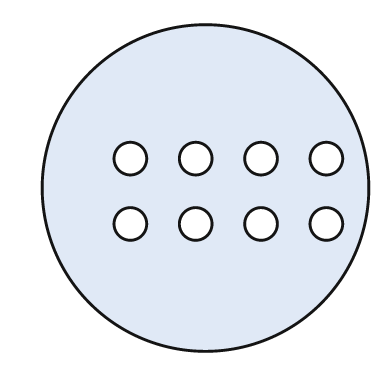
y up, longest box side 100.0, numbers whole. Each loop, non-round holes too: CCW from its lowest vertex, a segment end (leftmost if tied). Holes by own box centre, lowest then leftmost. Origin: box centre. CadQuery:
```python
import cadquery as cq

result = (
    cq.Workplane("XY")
    .moveTo(0.0, 0.0)
    .circle(50.0)
    .moveTo(-23.0, -11.0)
    .circle(5.0)
    .moveTo(-3.0, -11.0)
    .circle(5.0)
    .moveTo(17.0, -11.0)
    .circle(5.0)
    .moveTo(37.0, -11.0)
    .circle(5.0)
    .moveTo(-23.0, 9.0)
    .circle(5.0)
    .moveTo(-3.0, 9.0)
    .circle(5.0)
    .moveTo(17.0, 9.0)
    .circle(5.0)
    .moveTo(37.0, 9.0)
    .circle(5.0)
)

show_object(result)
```